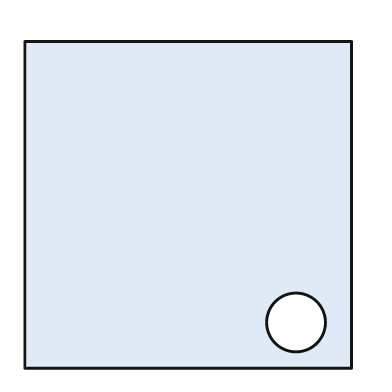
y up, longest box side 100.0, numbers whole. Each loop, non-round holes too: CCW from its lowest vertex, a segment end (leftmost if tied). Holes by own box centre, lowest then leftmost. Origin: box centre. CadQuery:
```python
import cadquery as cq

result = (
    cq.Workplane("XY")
    .moveTo(-50.0, -50.0)
    .lineTo(50.0, -50.0)
    .lineTo(50.0, 50.0)
    .lineTo(-50.0, 50.0)
    .close()
    .moveTo(33.0, -36.0)
    .circle(9.0)
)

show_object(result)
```